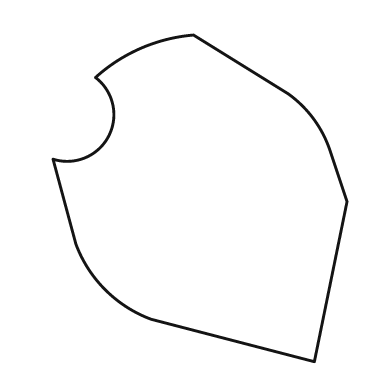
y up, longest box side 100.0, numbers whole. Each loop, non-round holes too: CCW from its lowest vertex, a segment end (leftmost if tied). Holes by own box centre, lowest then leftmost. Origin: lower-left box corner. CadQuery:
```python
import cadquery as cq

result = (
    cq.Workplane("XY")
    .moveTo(80.0, 0.0)
    .lineTo(90.0, 49.0)
    .lineTo(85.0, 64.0)
    .threePointArc((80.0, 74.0), (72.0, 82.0))
    .lineTo(43.0, 100.0)
    .threePointArc((27.0, 96.0), (13.0, 87.0))
    .threePointArc((17.0, 69.0), (0.0, 62.0))
    .lineTo(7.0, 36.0)
    .threePointArc((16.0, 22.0), (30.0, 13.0))
    .close()
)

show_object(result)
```